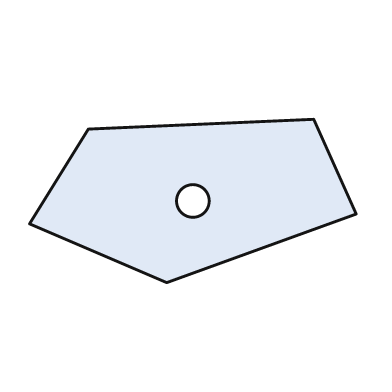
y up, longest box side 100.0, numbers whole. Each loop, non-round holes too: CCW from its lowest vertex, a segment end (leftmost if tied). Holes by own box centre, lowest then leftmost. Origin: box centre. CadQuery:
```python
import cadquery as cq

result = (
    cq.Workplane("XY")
    .moveTo(-8.0, -25.0)
    .lineTo(50.0, -4.0)
    .lineTo(37.0, 25.0)
    .lineTo(-32.0, 22.0)
    .lineTo(-50.0, -7.0)
    .close()
    .moveTo(0.0, 0.0)
    .circle(5.0)
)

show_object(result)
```